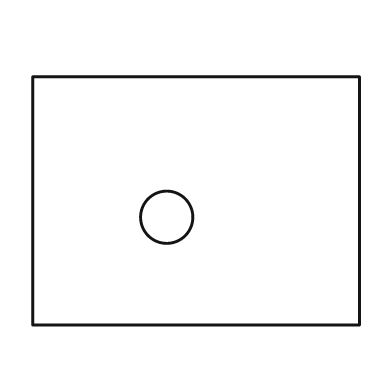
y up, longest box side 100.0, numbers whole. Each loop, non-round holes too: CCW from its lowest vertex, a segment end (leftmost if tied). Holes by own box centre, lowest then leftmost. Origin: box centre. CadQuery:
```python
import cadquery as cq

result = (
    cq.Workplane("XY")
    .moveTo(-50.0, -38.0)
    .lineTo(50.0, -38.0)
    .lineTo(50.0, 38.0)
    .lineTo(-50.0, 38.0)
    .close()
    .moveTo(-9.0, -5.0)
    .circle(8.0)
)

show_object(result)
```